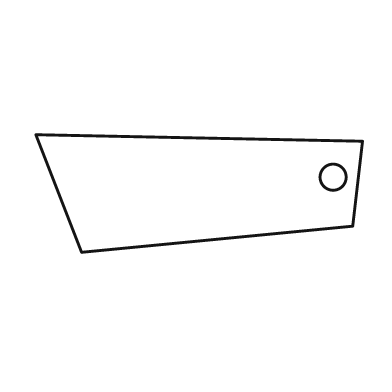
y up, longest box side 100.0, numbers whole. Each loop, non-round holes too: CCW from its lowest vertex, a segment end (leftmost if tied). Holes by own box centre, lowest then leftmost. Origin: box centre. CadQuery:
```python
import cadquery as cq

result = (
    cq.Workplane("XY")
    .moveTo(-36.0, -18.0)
    .lineTo(47.0, -10.0)
    .lineTo(50.0, 16.0)
    .lineTo(-50.0, 18.0)
    .close()
    .moveTo(41.0, 5.0)
    .circle(4.0)
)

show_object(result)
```